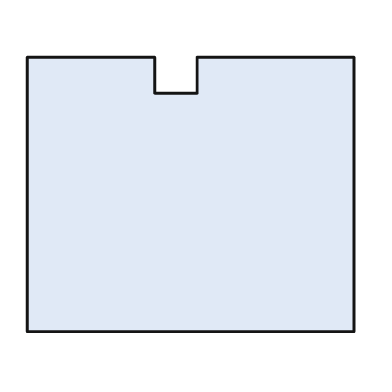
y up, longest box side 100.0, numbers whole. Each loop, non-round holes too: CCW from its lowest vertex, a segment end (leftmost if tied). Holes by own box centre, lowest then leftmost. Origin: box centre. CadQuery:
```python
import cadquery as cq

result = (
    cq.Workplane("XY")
    .moveTo(-50.0, -42.0)
    .lineTo(50.0, -42.0)
    .lineTo(50.0, 42.0)
    .lineTo(2.0, 42.0)
    .lineTo(2.0, 31.0)
    .lineTo(-11.0, 31.0)
    .lineTo(-11.0, 42.0)
    .lineTo(-50.0, 42.0)
    .close()
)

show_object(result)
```